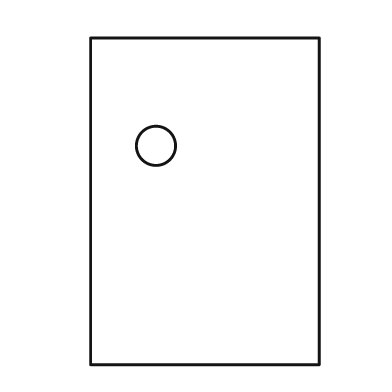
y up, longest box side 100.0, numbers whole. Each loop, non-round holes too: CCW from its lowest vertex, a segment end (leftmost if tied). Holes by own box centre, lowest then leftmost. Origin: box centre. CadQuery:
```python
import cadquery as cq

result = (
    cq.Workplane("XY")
    .moveTo(-35.0, -50.0)
    .lineTo(35.0, -50.0)
    .lineTo(35.0, 50.0)
    .lineTo(-35.0, 50.0)
    .close()
    .moveTo(-15.0, 17.0)
    .circle(6.0)
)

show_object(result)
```